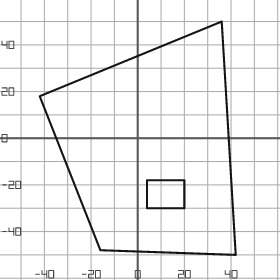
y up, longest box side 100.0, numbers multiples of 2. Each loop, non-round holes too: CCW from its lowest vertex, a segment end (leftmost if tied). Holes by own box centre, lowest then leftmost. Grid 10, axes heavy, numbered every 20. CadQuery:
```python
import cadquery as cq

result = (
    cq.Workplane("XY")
    .moveTo(42.0, -50.0)
    .lineTo(36.0, 50.0)
    .lineTo(-42.0, 18.0)
    .lineTo(-16.0, -48.0)
    .close()
    .moveTo(4.0, -30.0)
    .lineTo(20.0, -30.0)
    .lineTo(20.0, -18.0)
    .lineTo(4.0, -18.0)
    .close()
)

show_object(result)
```